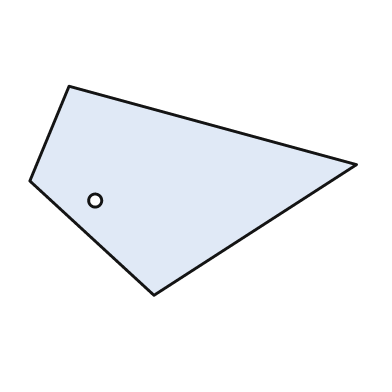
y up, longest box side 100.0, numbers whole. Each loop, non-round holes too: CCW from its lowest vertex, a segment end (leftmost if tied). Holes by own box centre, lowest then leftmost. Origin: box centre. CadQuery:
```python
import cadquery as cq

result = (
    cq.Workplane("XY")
    .moveTo(-12.0, -32.0)
    .lineTo(50.0, 8.0)
    .lineTo(-38.0, 32.0)
    .lineTo(-50.0, 3.0)
    .close()
    .moveTo(-30.0, -3.0)
    .circle(2.0)
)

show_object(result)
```